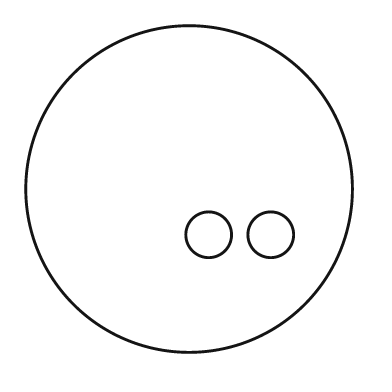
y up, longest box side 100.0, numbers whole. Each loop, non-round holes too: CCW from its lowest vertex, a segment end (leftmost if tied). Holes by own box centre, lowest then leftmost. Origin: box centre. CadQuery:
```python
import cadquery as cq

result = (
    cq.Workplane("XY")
    .moveTo(0.0, 0.0)
    .circle(50.0)
    .moveTo(6.0, -14.0)
    .circle(7.0)
    .moveTo(25.0, -14.0)
    .circle(7.0)
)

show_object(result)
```